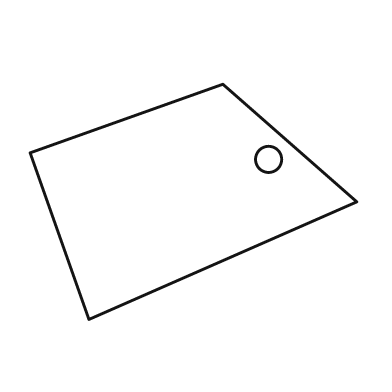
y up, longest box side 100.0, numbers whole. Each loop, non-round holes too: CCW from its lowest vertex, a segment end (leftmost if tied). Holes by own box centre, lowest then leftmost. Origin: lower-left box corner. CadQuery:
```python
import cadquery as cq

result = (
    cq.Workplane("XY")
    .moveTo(18.0, 0.0)
    .lineTo(100.0, 36.0)
    .lineTo(59.0, 72.0)
    .lineTo(0.0, 51.0)
    .close()
    .moveTo(73.0, 49.0)
    .circle(4.0)
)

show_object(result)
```